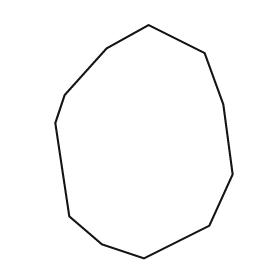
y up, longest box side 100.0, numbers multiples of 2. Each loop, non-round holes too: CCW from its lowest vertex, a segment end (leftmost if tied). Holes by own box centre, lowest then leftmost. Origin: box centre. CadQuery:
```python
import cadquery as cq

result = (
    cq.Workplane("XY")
    .moveTo(0.0, -50.0)
    .lineTo(28.0, -36.0)
    .lineTo(38.0, -14.0)
    .lineTo(34.0, 16.0)
    .lineTo(26.0, 38.0)
    .lineTo(2.0, 50.0)
    .lineTo(-16.0, 40.0)
    .lineTo(-34.0, 20.0)
    .lineTo(-38.0, 8.0)
    .lineTo(-32.0, -32.0)
    .lineTo(-18.0, -44.0)
    .close()
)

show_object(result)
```